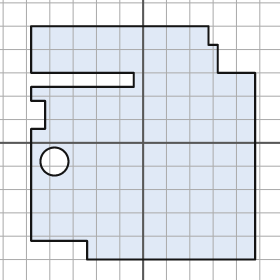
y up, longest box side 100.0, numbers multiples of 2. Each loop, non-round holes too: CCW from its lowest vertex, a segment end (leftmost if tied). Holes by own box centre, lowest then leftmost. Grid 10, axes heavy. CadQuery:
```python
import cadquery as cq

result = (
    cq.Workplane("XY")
    .moveTo(-24.0, -50.0)
    .lineTo(48.0, -50.0)
    .lineTo(48.0, 30.0)
    .lineTo(32.0, 30.0)
    .lineTo(32.0, 42.0)
    .lineTo(28.0, 42.0)
    .lineTo(28.0, 50.0)
    .lineTo(-48.0, 50.0)
    .lineTo(-48.0, 30.0)
    .lineTo(-4.0, 30.0)
    .lineTo(-4.0, 24.0)
    .lineTo(-48.0, 24.0)
    .lineTo(-48.0, 18.0)
    .lineTo(-42.0, 18.0)
    .lineTo(-42.0, 6.0)
    .lineTo(-48.0, 6.0)
    .lineTo(-48.0, -42.0)
    .lineTo(-24.0, -42.0)
    .close()
    .moveTo(-38.0, -8.0)
    .circle(6.0)
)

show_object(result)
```